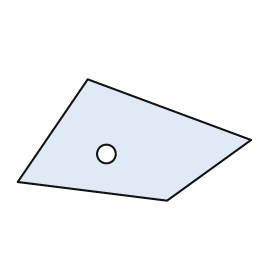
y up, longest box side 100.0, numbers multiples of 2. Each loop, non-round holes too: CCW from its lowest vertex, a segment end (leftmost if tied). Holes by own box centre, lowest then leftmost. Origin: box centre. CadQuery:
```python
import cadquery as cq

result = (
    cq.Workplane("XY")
    .moveTo(14.0, -26.0)
    .lineTo(50.0, 0.0)
    .lineTo(-20.0, 26.0)
    .lineTo(-50.0, -18.0)
    .close()
    .moveTo(-12.0, -6.0)
    .circle(4.0)
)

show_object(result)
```